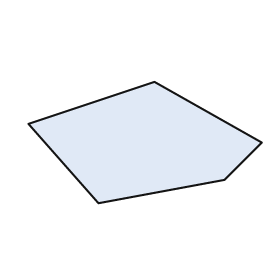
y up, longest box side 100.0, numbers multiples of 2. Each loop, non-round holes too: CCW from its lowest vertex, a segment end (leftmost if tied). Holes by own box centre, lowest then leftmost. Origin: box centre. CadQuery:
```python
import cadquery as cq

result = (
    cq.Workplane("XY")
    .moveTo(-20.0, -26.0)
    .lineTo(34.0, -16.0)
    .lineTo(50.0, 0.0)
    .lineTo(4.0, 26.0)
    .lineTo(-50.0, 8.0)
    .close()
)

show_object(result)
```